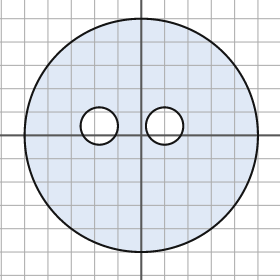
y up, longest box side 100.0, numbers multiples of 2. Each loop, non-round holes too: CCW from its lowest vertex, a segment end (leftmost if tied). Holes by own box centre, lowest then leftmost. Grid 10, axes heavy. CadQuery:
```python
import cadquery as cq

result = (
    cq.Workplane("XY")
    .moveTo(0.0, 0.0)
    .circle(50.0)
    .moveTo(-18.0, 4.0)
    .circle(8.0)
    .moveTo(10.0, 4.0)
    .circle(8.0)
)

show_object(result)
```